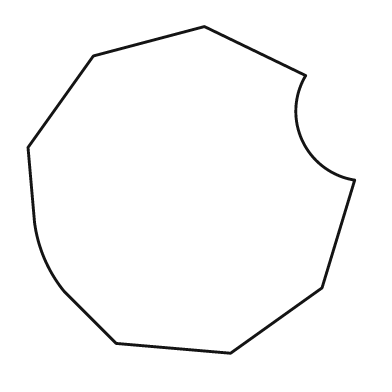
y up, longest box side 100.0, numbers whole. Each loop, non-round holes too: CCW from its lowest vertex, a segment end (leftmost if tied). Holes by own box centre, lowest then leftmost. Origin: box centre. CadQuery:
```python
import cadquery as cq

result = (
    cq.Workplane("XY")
    .moveTo(12.0, -50.0)
    .lineTo(40.0, -30.0)
    .lineTo(50.0, 3.0)
    .threePointArc((34.0, 15.0), (35.0, 35.0))
    .lineTo(4.0, 50.0)
    .lineTo(-30.0, 41.0)
    .lineTo(-50.0, 13.0)
    .lineTo(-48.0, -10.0)
    .threePointArc((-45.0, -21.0), (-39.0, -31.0))
    .lineTo(-23.0, -47.0)
    .close()
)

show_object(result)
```